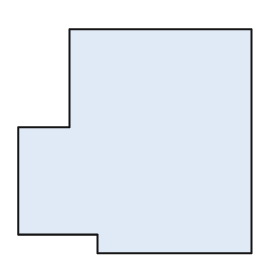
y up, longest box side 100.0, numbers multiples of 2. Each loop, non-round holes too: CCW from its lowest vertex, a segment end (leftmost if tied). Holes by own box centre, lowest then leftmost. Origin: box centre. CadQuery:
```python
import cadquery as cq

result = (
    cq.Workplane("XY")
    .moveTo(-16.0, -48.0)
    .lineTo(50.0, -48.0)
    .lineTo(50.0, 48.0)
    .lineTo(-28.0, 48.0)
    .lineTo(-28.0, 6.0)
    .lineTo(-50.0, 6.0)
    .lineTo(-50.0, -40.0)
    .lineTo(-16.0, -40.0)
    .close()
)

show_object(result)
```